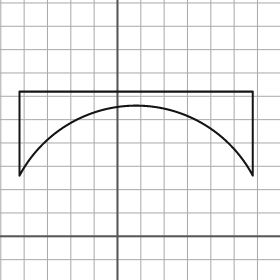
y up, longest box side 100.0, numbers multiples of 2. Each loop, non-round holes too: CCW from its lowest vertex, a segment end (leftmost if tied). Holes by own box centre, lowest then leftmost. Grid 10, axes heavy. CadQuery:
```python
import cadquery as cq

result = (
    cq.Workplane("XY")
    .moveTo(-42.0, 26.0)
    .threePointArc((8.0, 56.0), (58.0, 26.0))
    .lineTo(58.0, 62.0)
    .lineTo(-42.0, 62.0)
    .close()
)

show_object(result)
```